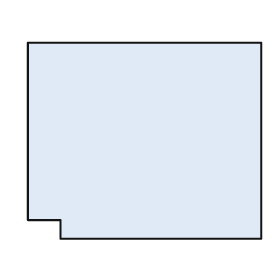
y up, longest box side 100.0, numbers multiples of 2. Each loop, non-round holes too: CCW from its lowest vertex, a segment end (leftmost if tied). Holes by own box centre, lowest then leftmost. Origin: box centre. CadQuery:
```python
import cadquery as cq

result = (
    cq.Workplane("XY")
    .moveTo(-36.0, -42.0)
    .lineTo(50.0, -42.0)
    .lineTo(50.0, 42.0)
    .lineTo(-50.0, 42.0)
    .lineTo(-50.0, -34.0)
    .lineTo(-36.0, -34.0)
    .close()
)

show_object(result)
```